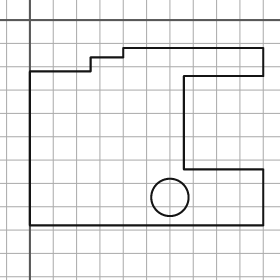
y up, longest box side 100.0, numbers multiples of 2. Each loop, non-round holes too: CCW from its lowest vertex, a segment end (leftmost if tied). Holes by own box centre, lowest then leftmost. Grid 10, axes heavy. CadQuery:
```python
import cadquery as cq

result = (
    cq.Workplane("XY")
    .moveTo(0.0, -88.0)
    .lineTo(100.0, -88.0)
    .lineTo(100.0, -64.0)
    .lineTo(66.0, -64.0)
    .lineTo(66.0, -24.0)
    .lineTo(100.0, -24.0)
    .lineTo(100.0, -12.0)
    .lineTo(40.0, -12.0)
    .lineTo(40.0, -16.0)
    .lineTo(26.0, -16.0)
    .lineTo(26.0, -22.0)
    .lineTo(0.0, -22.0)
    .close()
    .moveTo(60.0, -76.0)
    .circle(8.0)
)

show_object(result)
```